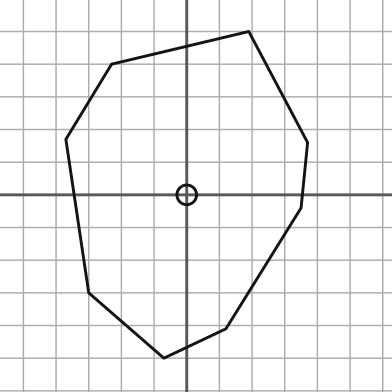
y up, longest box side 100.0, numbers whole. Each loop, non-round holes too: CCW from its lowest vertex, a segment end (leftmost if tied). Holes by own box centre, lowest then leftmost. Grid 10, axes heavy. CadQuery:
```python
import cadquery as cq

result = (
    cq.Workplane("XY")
    .moveTo(-7.0, -50.0)
    .lineTo(12.0, -41.0)
    .lineTo(35.0, -4.0)
    .lineTo(37.0, 16.0)
    .lineTo(19.0, 50.0)
    .lineTo(-23.0, 40.0)
    .lineTo(-37.0, 17.0)
    .lineTo(-30.0, -30.0)
    .close()
    .moveTo(0.0, 0.0)
    .circle(3.0)
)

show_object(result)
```